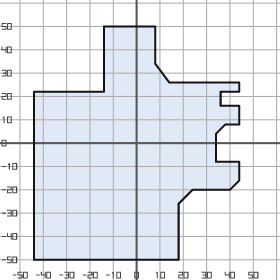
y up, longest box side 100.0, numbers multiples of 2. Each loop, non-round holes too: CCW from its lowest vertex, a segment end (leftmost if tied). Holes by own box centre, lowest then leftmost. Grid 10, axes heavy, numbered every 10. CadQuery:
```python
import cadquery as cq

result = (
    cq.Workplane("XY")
    .moveTo(-44.0, -50.0)
    .lineTo(18.0, -50.0)
    .lineTo(18.0, -26.0)
    .lineTo(24.0, -20.0)
    .lineTo(40.0, -20.0)
    .lineTo(44.0, -16.0)
    .lineTo(44.0, -8.0)
    .lineTo(34.0, -8.0)
    .lineTo(34.0, 4.0)
    .lineTo(38.0, 8.0)
    .lineTo(44.0, 8.0)
    .lineTo(44.0, 16.0)
    .lineTo(36.0, 16.0)
    .lineTo(36.0, 22.0)
    .lineTo(44.0, 22.0)
    .lineTo(44.0, 26.0)
    .lineTo(14.0, 26.0)
    .lineTo(8.0, 34.0)
    .lineTo(8.0, 50.0)
    .lineTo(-14.0, 50.0)
    .lineTo(-14.0, 22.0)
    .lineTo(-44.0, 22.0)
    .close()
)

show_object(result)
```